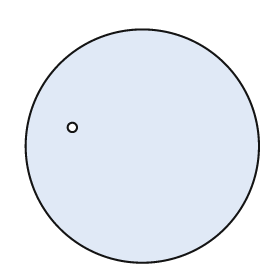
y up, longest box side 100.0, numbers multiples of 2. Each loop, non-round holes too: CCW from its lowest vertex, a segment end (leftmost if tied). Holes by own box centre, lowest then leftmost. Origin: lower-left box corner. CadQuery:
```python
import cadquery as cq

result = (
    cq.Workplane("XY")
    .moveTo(50.0, 50.0)
    .circle(50.0)
    .moveTo(20.0, 58.0)
    .circle(2.0)
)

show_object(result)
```